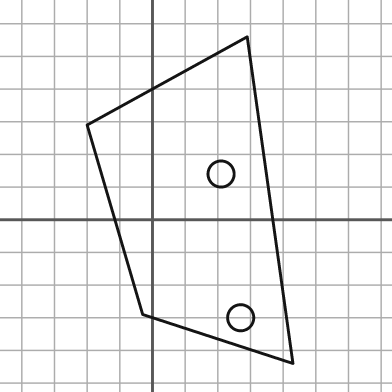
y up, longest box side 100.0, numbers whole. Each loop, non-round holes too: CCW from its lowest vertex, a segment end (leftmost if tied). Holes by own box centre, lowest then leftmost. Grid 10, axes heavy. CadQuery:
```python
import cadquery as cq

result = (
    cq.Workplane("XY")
    .moveTo(43.0, -44.0)
    .lineTo(29.0, 56.0)
    .lineTo(-20.0, 29.0)
    .lineTo(-3.0, -29.0)
    .close()
    .moveTo(27.0, -30.0)
    .circle(4.0)
    .moveTo(21.0, 14.0)
    .circle(4.0)
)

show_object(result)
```